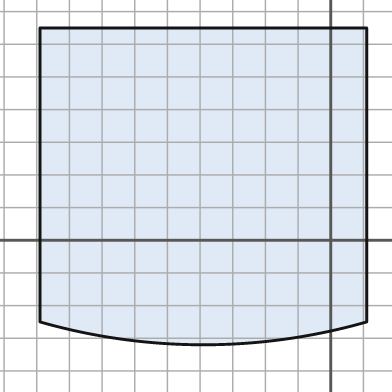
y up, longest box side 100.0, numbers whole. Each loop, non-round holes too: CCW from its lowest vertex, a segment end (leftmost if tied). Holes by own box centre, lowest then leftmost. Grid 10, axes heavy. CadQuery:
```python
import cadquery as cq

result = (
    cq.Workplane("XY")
    .moveTo(-89.0, -25.0)
    .threePointArc((-39.0, -32.0), (11.0, -25.0))
    .lineTo(11.0, 65.0)
    .lineTo(-89.0, 65.0)
    .close()
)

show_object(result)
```